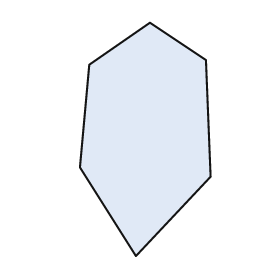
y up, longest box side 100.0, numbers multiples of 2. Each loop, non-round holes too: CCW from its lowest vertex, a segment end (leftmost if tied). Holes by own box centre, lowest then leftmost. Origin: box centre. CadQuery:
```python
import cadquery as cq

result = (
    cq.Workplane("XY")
    .moveTo(-4.0, -50.0)
    .lineTo(28.0, -16.0)
    .lineTo(26.0, 34.0)
    .lineTo(2.0, 50.0)
    .lineTo(-24.0, 32.0)
    .lineTo(-28.0, -12.0)
    .close()
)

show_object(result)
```